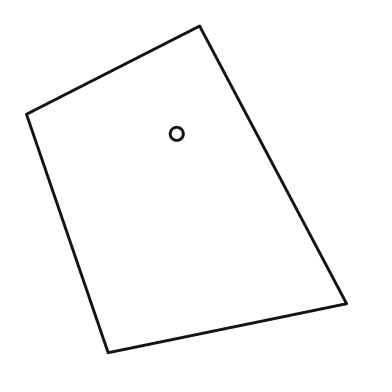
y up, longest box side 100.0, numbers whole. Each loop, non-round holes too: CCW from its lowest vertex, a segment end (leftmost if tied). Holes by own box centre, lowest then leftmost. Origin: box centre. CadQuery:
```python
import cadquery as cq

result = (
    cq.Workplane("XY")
    .moveTo(-24.0, -50.0)
    .lineTo(49.0, -35.0)
    .lineTo(4.0, 50.0)
    .lineTo(-49.0, 23.0)
    .close()
    .moveTo(-3.0, 17.0)
    .circle(2.0)
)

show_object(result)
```